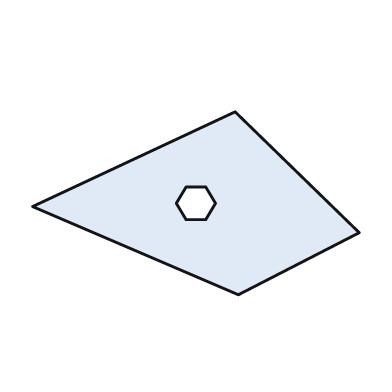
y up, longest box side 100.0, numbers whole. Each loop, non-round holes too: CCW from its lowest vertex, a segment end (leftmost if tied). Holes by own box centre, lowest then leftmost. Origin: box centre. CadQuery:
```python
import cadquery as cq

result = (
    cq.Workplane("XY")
    .moveTo(13.0, -28.0)
    .lineTo(50.0, -9.0)
    .lineTo(12.0, 28.0)
    .lineTo(-50.0, -1.0)
    .close()
    .moveTo(-3.0, -5.0)
    .lineTo(3.0, -5.0)
    .lineTo(6.0, 0.0)
    .lineTo(3.0, 5.0)
    .lineTo(-3.0, 5.0)
    .lineTo(-6.0, 0.0)
    .close()
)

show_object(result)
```